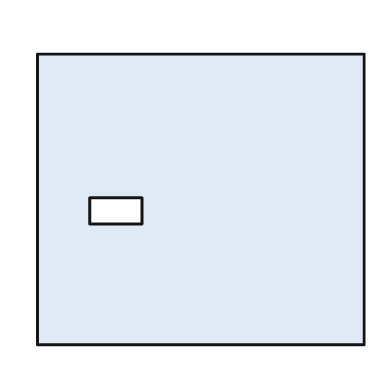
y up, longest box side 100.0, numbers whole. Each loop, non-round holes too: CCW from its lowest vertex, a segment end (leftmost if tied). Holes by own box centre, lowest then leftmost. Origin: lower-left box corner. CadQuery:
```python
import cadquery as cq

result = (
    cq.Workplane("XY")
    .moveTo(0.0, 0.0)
    .lineTo(100.0, 0.0)
    .lineTo(100.0, 89.0)
    .lineTo(0.0, 89.0)
    .close()
    .moveTo(16.0, 37.0)
    .lineTo(32.0, 37.0)
    .lineTo(32.0, 45.0)
    .lineTo(16.0, 45.0)
    .close()
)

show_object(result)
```